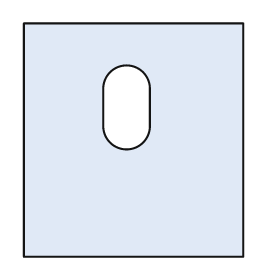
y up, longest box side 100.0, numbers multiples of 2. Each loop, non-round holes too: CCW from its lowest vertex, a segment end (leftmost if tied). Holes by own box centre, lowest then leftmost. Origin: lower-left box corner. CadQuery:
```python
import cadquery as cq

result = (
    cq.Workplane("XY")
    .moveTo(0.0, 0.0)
    .lineTo(94.0, 0.0)
    .lineTo(94.0, 100.0)
    .lineTo(0.0, 100.0)
    .close()
    .moveTo(34.0, 56.0)
    .threePointArc((44.0, 46.0), (54.0, 56.0))
    .lineTo(54.0, 72.0)
    .threePointArc((44.0, 82.0), (34.0, 72.0))
    .close()
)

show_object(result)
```